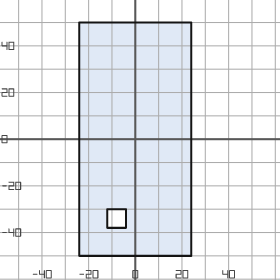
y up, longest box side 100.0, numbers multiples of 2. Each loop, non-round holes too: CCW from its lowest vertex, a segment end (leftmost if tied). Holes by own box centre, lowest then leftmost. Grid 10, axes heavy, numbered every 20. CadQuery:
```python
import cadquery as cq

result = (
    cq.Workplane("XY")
    .moveTo(-24.0, -50.0)
    .lineTo(24.0, -50.0)
    .lineTo(24.0, 50.0)
    .lineTo(-24.0, 50.0)
    .close()
    .moveTo(-12.0, -38.0)
    .lineTo(-4.0, -38.0)
    .lineTo(-4.0, -30.0)
    .lineTo(-12.0, -30.0)
    .close()
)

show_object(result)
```